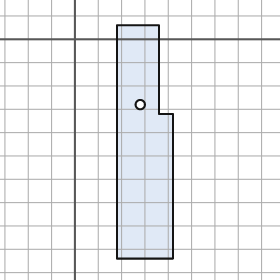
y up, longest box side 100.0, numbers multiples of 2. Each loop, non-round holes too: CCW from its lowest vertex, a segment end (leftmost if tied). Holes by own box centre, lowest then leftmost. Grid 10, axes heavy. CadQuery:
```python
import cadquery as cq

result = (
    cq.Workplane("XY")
    .moveTo(18.0, -94.0)
    .lineTo(42.0, -94.0)
    .lineTo(42.0, -32.0)
    .lineTo(36.0, -32.0)
    .lineTo(36.0, 6.0)
    .lineTo(18.0, 6.0)
    .close()
    .moveTo(28.0, -28.0)
    .circle(2.0)
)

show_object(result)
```